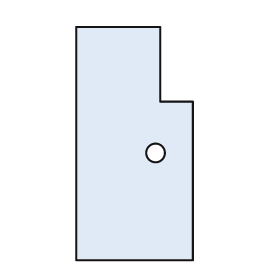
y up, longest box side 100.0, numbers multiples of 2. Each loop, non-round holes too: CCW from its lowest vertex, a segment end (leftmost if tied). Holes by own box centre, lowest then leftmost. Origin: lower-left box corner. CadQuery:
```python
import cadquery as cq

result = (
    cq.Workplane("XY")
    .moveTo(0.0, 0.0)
    .lineTo(50.0, 0.0)
    .lineTo(50.0, 68.0)
    .lineTo(36.0, 68.0)
    .lineTo(36.0, 100.0)
    .lineTo(0.0, 100.0)
    .close()
    .moveTo(34.0, 46.0)
    .circle(4.0)
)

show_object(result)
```